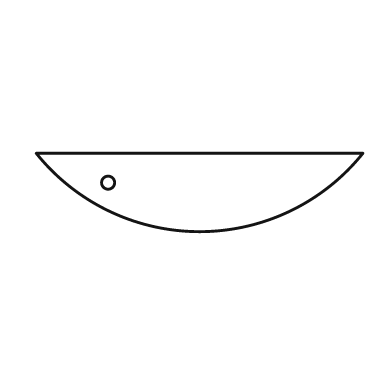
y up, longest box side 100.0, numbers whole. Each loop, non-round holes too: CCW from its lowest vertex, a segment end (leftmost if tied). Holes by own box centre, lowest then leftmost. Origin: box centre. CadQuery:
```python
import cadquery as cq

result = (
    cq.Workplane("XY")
    .moveTo(-50.0, 12.0)
    .threePointArc((0.0, -12.0), (50.0, 12.0))
    .close()
    .moveTo(-28.0, 3.0)
    .circle(2.0)
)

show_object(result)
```